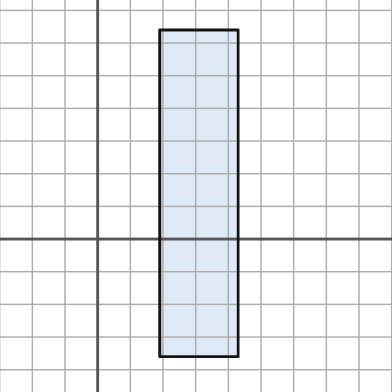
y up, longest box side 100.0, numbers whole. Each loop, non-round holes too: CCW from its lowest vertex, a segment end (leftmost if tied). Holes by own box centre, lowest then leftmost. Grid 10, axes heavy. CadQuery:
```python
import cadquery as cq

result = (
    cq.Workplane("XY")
    .moveTo(19.0, -36.0)
    .lineTo(43.0, -36.0)
    .lineTo(43.0, 64.0)
    .lineTo(19.0, 64.0)
    .close()
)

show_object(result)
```